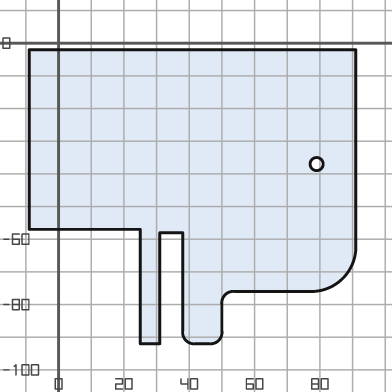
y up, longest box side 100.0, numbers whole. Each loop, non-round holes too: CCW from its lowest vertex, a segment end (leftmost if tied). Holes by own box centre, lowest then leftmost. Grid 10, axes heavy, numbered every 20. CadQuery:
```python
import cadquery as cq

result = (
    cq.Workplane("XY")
    .moveTo(25.0, -92.0)
    .lineTo(31.0, -92.0)
    .lineTo(31.0, -58.0)
    .lineTo(38.0, -58.0)
    .lineTo(38.0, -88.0)
    .threePointArc((39.0, -91.0), (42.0, -92.0))
    .lineTo(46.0, -92.0)
    .threePointArc((49.0, -91.0), (50.0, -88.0))
    .lineTo(50.0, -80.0)
    .threePointArc((51.0, -77.0), (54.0, -76.0))
    .lineTo(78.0, -76.0)
    .threePointArc((87.0, -72.0), (91.0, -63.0))
    .lineTo(91.0, -2.0)
    .lineTo(-9.0, -2.0)
    .lineTo(-9.0, -57.0)
    .lineTo(25.0, -57.0)
    .close()
    .moveTo(79.0, -37.0)
    .circle(2.0)
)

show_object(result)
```